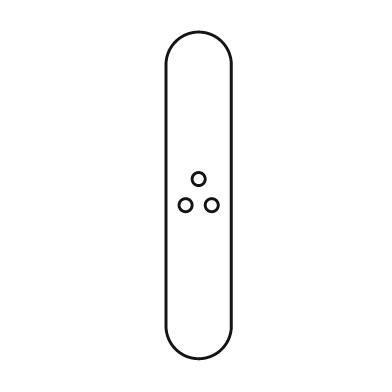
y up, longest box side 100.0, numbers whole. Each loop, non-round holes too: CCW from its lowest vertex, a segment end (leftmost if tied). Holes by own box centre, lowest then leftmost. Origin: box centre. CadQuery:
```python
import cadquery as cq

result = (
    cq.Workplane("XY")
    .moveTo(-10.0, -40.0)
    .threePointArc((0.0, -50.0), (10.0, -40.0))
    .lineTo(10.0, 40.0)
    .threePointArc((0.0, 50.0), (-10.0, 40.0))
    .close()
    .moveTo(-4.0, -3.0)
    .circle(2.0)
    .moveTo(4.0, -3.0)
    .circle(2.0)
    .moveTo(0.0, 5.0)
    .circle(2.0)
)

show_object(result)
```